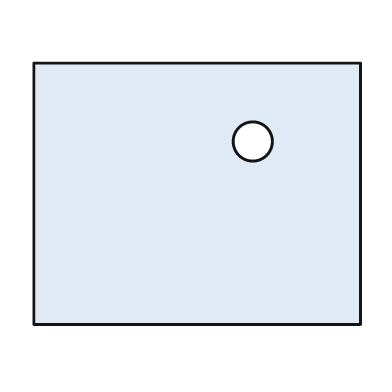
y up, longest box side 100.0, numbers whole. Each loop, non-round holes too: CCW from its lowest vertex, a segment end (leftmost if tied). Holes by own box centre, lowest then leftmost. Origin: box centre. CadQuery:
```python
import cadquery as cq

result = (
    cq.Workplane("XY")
    .moveTo(-50.0, -40.0)
    .lineTo(50.0, -40.0)
    .lineTo(50.0, 40.0)
    .lineTo(-50.0, 40.0)
    .close()
    .moveTo(17.0, 16.0)
    .circle(6.0)
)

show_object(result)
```